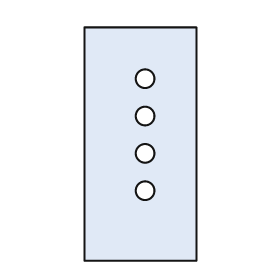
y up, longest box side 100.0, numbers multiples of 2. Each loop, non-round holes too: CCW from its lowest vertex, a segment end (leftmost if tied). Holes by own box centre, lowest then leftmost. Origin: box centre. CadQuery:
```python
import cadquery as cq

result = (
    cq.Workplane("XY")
    .moveTo(-24.0, -50.0)
    .lineTo(24.0, -50.0)
    .lineTo(24.0, 50.0)
    .lineTo(-24.0, 50.0)
    .close()
    .moveTo(2.0, -20.0)
    .circle(4.0)
    .moveTo(2.0, -4.0)
    .circle(4.0)
    .moveTo(2.0, 12.0)
    .circle(4.0)
    .moveTo(2.0, 28.0)
    .circle(4.0)
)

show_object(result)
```